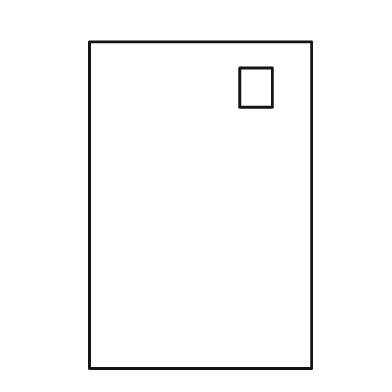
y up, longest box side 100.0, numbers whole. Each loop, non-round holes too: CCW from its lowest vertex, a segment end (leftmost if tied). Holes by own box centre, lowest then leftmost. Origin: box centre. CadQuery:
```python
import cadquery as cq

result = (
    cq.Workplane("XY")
    .moveTo(-34.0, -50.0)
    .lineTo(34.0, -50.0)
    .lineTo(34.0, 50.0)
    .lineTo(-34.0, 50.0)
    .close()
    .moveTo(12.0, 30.0)
    .lineTo(22.0, 30.0)
    .lineTo(22.0, 42.0)
    .lineTo(12.0, 42.0)
    .close()
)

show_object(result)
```